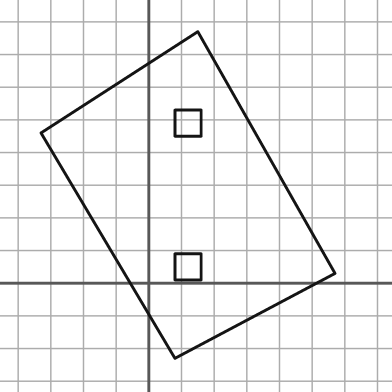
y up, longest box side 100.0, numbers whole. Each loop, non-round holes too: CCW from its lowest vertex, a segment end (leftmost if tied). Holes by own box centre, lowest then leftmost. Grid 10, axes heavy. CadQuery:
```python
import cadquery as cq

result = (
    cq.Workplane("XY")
    .moveTo(8.0, -23.0)
    .lineTo(57.0, 3.0)
    .lineTo(15.0, 77.0)
    .lineTo(-33.0, 46.0)
    .close()
    .moveTo(8.0, 1.0)
    .lineTo(16.0, 1.0)
    .lineTo(16.0, 9.0)
    .lineTo(8.0, 9.0)
    .close()
    .moveTo(8.0, 45.0)
    .lineTo(16.0, 45.0)
    .lineTo(16.0, 53.0)
    .lineTo(8.0, 53.0)
    .close()
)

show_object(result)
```